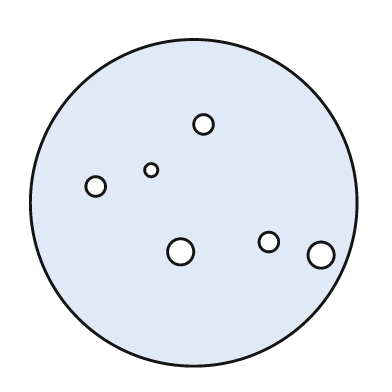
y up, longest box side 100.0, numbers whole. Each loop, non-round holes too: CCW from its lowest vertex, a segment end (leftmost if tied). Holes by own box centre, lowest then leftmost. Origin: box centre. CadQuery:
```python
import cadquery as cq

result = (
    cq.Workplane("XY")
    .moveTo(0.0, 0.0)
    .circle(50.0)
    .moveTo(39.0, -16.0)
    .circle(4.0)
    .moveTo(-4.0, -15.0)
    .circle(4.0)
    .moveTo(23.0, -12.0)
    .circle(3.0)
    .moveTo(-30.0, 5.0)
    .circle(3.0)
    .moveTo(-13.0, 10.0)
    .circle(2.0)
    .moveTo(3.0, 24.0)
    .circle(3.0)
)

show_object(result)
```